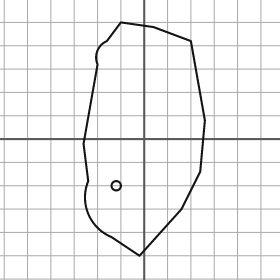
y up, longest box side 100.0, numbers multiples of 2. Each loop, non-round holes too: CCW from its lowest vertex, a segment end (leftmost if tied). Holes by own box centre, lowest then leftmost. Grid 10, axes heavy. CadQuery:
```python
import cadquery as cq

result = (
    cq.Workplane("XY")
    .moveTo(-2.0, -50.0)
    .lineTo(16.0, -30.0)
    .lineTo(24.0, -14.0)
    .lineTo(26.0, 8.0)
    .lineTo(20.0, 42.0)
    .lineTo(4.0, 48.0)
    .lineTo(-10.0, 50.0)
    .lineTo(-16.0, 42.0)
    .threePointArc((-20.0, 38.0), (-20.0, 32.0))
    .lineTo(-26.0, -2.0)
    .lineTo(-24.0, -18.0)
    .threePointArc((-24.0, -32.0), (-14.0, -42.0))
    .close()
    .moveTo(-12.0, -20.0)
    .circle(2.0)
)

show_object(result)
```